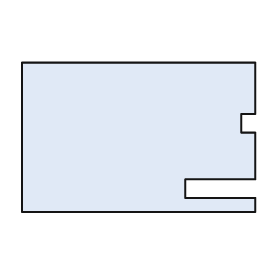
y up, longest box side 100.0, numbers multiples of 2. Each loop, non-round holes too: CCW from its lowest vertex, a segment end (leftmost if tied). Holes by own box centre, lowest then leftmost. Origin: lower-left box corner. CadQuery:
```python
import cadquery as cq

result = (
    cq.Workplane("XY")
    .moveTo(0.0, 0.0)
    .lineTo(100.0, 0.0)
    .lineTo(100.0, 6.0)
    .lineTo(70.0, 6.0)
    .lineTo(70.0, 14.0)
    .lineTo(100.0, 14.0)
    .lineTo(100.0, 34.0)
    .lineTo(94.0, 34.0)
    .lineTo(94.0, 42.0)
    .lineTo(100.0, 42.0)
    .lineTo(100.0, 64.0)
    .lineTo(0.0, 64.0)
    .close()
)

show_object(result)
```